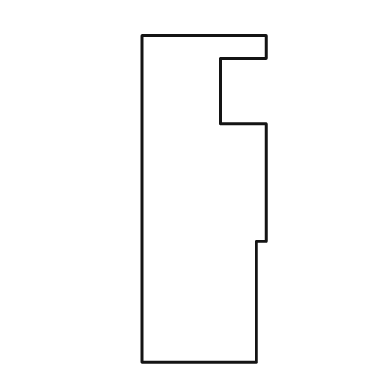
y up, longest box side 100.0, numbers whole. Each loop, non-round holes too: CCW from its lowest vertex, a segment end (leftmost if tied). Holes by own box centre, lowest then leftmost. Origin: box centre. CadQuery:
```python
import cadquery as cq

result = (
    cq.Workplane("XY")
    .moveTo(-19.0, -50.0)
    .lineTo(16.0, -50.0)
    .lineTo(16.0, -13.0)
    .lineTo(19.0, -13.0)
    .lineTo(19.0, 23.0)
    .lineTo(5.0, 23.0)
    .lineTo(5.0, 43.0)
    .lineTo(19.0, 43.0)
    .lineTo(19.0, 50.0)
    .lineTo(-19.0, 50.0)
    .close()
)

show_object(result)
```